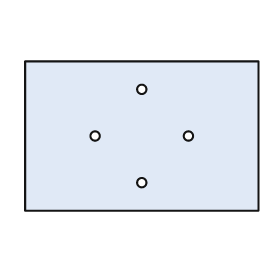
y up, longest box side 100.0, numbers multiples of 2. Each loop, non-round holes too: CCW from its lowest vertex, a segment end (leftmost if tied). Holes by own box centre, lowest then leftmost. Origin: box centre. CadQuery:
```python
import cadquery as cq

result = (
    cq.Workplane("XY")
    .moveTo(-50.0, -32.0)
    .lineTo(50.0, -32.0)
    .lineTo(50.0, 32.0)
    .lineTo(-50.0, 32.0)
    .close()
    .moveTo(0.0, -20.0)
    .circle(2.0)
    .moveTo(-20.0, 0.0)
    .circle(2.0)
    .moveTo(20.0, 0.0)
    .circle(2.0)
    .moveTo(0.0, 20.0)
    .circle(2.0)
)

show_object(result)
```